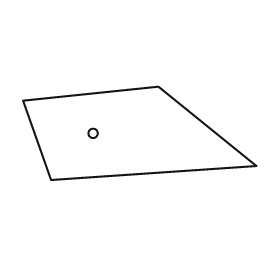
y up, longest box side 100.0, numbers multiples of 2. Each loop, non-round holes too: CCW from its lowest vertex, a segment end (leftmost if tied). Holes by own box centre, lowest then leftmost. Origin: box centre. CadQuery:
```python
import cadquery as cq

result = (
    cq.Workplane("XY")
    .moveTo(-38.0, -20.0)
    .lineTo(50.0, -14.0)
    .lineTo(8.0, 20.0)
    .lineTo(-50.0, 14.0)
    .close()
    .moveTo(-20.0, 0.0)
    .circle(2.0)
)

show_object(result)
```